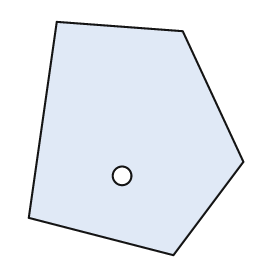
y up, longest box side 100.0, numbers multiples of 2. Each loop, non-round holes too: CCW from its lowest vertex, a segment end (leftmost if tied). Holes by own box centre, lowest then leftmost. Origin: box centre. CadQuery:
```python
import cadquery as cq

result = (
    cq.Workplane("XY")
    .moveTo(16.0, -50.0)
    .lineTo(46.0, -10.0)
    .lineTo(20.0, 46.0)
    .lineTo(-34.0, 50.0)
    .lineTo(-46.0, -34.0)
    .close()
    .moveTo(-6.0, -16.0)
    .circle(4.0)
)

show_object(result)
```